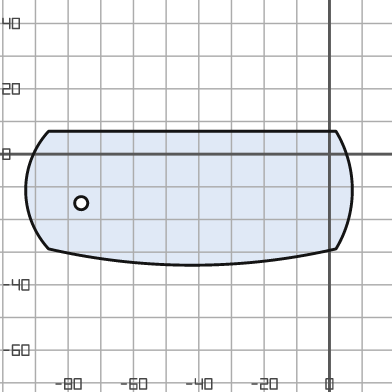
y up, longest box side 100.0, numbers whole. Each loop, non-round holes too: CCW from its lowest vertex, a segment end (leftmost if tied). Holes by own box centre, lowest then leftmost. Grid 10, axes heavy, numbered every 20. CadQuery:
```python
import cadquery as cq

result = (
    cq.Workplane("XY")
    .moveTo(-86.0, -29.0)
    .threePointArc((-42.0, -34.0), (2.0, -29.0))
    .threePointArc((7.0, -11.0), (2.0, 7.0))
    .lineTo(-86.0, 7.0)
    .threePointArc((-93.0, -11.0), (-86.0, -29.0))
    .close()
    .moveTo(-76.0, -15.0)
    .circle(2.0)
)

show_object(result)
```